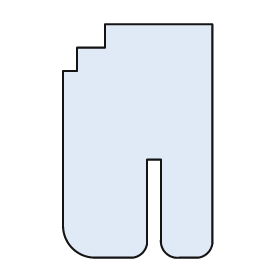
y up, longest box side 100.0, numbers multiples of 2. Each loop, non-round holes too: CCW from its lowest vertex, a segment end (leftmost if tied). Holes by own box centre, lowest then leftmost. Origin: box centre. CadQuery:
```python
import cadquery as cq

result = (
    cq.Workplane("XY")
    .moveTo(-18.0, -50.0)
    .lineTo(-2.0, -50.0)
    .threePointArc((2.0, -48.0), (4.0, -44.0))
    .lineTo(4.0, -8.0)
    .lineTo(10.0, -8.0)
    .lineTo(10.0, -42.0)
    .threePointArc((12.0, -48.0), (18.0, -50.0))
    .lineTo(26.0, -50.0)
    .threePointArc((30.0, -48.0), (32.0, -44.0))
    .lineTo(32.0, 50.0)
    .lineTo(-14.0, 50.0)
    .lineTo(-14.0, 40.0)
    .lineTo(-26.0, 40.0)
    .lineTo(-26.0, 30.0)
    .lineTo(-32.0, 30.0)
    .lineTo(-32.0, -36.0)
    .threePointArc((-28.0, -46.0), (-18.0, -50.0))
    .close()
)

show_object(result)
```